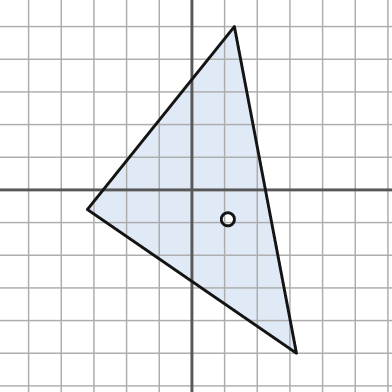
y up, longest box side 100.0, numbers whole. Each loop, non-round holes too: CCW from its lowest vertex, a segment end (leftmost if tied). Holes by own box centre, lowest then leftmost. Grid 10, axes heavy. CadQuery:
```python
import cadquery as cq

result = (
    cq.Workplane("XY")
    .moveTo(32.0, -50.0)
    .lineTo(13.0, 50.0)
    .lineTo(-32.0, -6.0)
    .close()
    .moveTo(11.0, -9.0)
    .circle(2.0)
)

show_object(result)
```